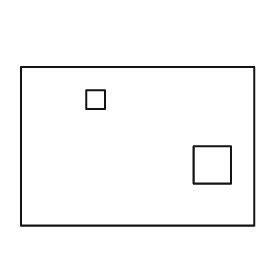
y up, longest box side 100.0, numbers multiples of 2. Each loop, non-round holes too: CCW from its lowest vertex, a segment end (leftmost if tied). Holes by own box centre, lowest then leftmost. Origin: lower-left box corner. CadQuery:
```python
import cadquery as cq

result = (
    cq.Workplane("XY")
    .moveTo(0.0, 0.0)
    .lineTo(100.0, 0.0)
    .lineTo(100.0, 68.0)
    .lineTo(0.0, 68.0)
    .close()
    .moveTo(74.0, 18.0)
    .lineTo(90.0, 18.0)
    .lineTo(90.0, 34.0)
    .lineTo(74.0, 34.0)
    .close()
    .moveTo(28.0, 50.0)
    .lineTo(36.0, 50.0)
    .lineTo(36.0, 58.0)
    .lineTo(28.0, 58.0)
    .close()
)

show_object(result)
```